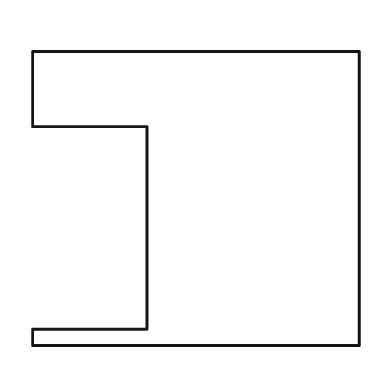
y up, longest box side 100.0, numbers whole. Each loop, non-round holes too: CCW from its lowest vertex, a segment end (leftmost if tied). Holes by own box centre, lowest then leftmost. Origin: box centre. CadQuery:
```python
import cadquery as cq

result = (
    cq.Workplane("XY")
    .moveTo(-50.0, -45.0)
    .lineTo(50.0, -45.0)
    .lineTo(50.0, 45.0)
    .lineTo(-50.0, 45.0)
    .lineTo(-50.0, 22.0)
    .lineTo(-15.0, 22.0)
    .lineTo(-15.0, -40.0)
    .lineTo(-50.0, -40.0)
    .close()
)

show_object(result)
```